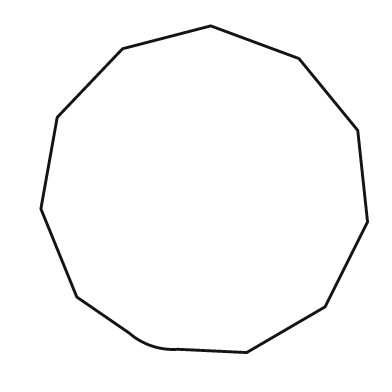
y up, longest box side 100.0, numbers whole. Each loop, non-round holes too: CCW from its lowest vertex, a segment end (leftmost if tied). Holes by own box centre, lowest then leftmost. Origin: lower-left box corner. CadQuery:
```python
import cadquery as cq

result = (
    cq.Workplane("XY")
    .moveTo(63.0, 0.0)
    .lineTo(87.0, 14.0)
    .lineTo(100.0, 40.0)
    .lineTo(97.0, 68.0)
    .lineTo(79.0, 90.0)
    .lineTo(52.0, 100.0)
    .lineTo(25.0, 93.0)
    .lineTo(5.0, 72.0)
    .lineTo(0.0, 44.0)
    .lineTo(11.0, 17.0)
    .lineTo(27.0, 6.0)
    .threePointArc((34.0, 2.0), (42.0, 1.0))
    .close()
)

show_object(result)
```